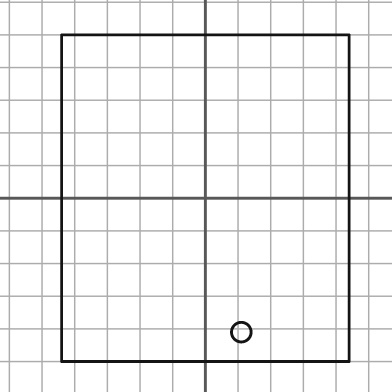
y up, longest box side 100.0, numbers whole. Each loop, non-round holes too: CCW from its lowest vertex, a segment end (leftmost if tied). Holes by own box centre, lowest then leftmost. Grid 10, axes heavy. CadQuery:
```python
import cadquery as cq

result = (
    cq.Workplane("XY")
    .moveTo(-44.0, -50.0)
    .lineTo(44.0, -50.0)
    .lineTo(44.0, 50.0)
    .lineTo(-44.0, 50.0)
    .close()
    .moveTo(11.0, -41.0)
    .circle(3.0)
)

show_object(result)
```